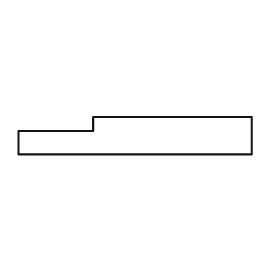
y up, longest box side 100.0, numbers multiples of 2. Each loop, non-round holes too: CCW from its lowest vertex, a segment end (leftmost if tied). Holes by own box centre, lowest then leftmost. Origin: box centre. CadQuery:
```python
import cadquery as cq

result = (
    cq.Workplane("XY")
    .moveTo(-50.0, -8.0)
    .lineTo(50.0, -8.0)
    .lineTo(50.0, 8.0)
    .lineTo(-18.0, 8.0)
    .lineTo(-18.0, 2.0)
    .lineTo(-50.0, 2.0)
    .close()
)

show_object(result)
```